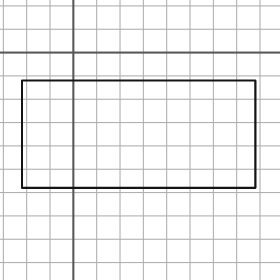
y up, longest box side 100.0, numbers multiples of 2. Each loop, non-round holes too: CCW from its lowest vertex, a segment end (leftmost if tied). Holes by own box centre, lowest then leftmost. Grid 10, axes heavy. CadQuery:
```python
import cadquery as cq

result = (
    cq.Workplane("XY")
    .moveTo(-22.0, -58.0)
    .lineTo(78.0, -58.0)
    .lineTo(78.0, -12.0)
    .lineTo(-22.0, -12.0)
    .close()
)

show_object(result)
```